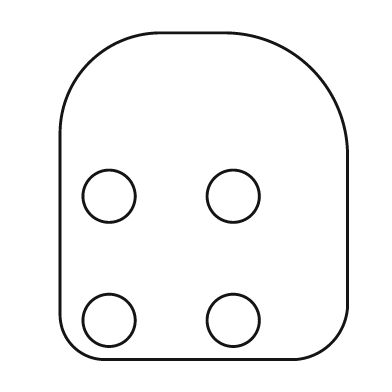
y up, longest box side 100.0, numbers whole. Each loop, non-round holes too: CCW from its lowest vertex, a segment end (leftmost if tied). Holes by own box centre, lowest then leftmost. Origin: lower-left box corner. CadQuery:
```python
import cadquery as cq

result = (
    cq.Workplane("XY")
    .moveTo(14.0, 0.0)
    .lineTo(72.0, 0.0)
    .threePointArc((83.0, 5.0), (88.0, 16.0))
    .lineTo(88.0, 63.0)
    .threePointArc((77.0, 89.0), (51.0, 100.0))
    .lineTo(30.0, 100.0)
    .threePointArc((9.0, 91.0), (0.0, 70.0))
    .lineTo(0.0, 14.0)
    .threePointArc((4.0, 4.0), (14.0, 0.0))
    .close()
    .moveTo(15.0, 12.0)
    .circle(8.0)
    .moveTo(53.0, 12.0)
    .circle(8.0)
    .moveTo(15.0, 50.0)
    .circle(8.0)
    .moveTo(53.0, 50.0)
    .circle(8.0)
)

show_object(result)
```